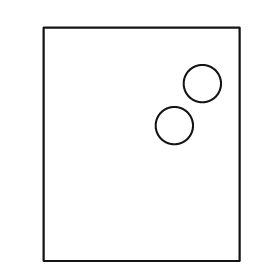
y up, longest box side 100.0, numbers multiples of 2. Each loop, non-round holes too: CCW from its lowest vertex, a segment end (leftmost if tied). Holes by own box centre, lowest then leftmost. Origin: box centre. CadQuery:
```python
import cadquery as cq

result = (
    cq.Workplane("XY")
    .moveTo(-42.0, -50.0)
    .lineTo(42.0, -50.0)
    .lineTo(42.0, 50.0)
    .lineTo(-42.0, 50.0)
    .close()
    .moveTo(14.0, 8.0)
    .circle(8.0)
    .moveTo(26.0, 26.0)
    .circle(8.0)
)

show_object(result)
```